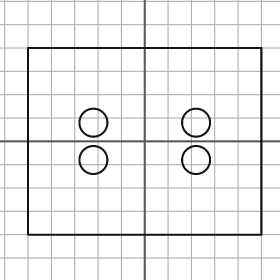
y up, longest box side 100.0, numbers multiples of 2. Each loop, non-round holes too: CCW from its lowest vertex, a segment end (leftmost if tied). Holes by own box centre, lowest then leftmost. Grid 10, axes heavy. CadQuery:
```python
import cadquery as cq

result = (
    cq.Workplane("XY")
    .moveTo(-50.0, -40.0)
    .lineTo(50.0, -40.0)
    .lineTo(50.0, 40.0)
    .lineTo(-50.0, 40.0)
    .close()
    .moveTo(-22.0, -8.0)
    .circle(6.0)
    .moveTo(22.0, -8.0)
    .circle(6.0)
    .moveTo(-22.0, 8.0)
    .circle(6.0)
    .moveTo(22.0, 8.0)
    .circle(6.0)
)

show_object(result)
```